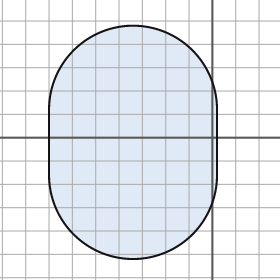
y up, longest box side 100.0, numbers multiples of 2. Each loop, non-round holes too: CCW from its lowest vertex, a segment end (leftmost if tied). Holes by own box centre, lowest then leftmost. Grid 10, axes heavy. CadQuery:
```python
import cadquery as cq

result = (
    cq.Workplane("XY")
    .moveTo(-70.0, -16.0)
    .threePointArc((-34.0, -52.0), (2.0, -16.0))
    .lineTo(2.0, 12.0)
    .threePointArc((-34.0, 48.0), (-70.0, 12.0))
    .close()
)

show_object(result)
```